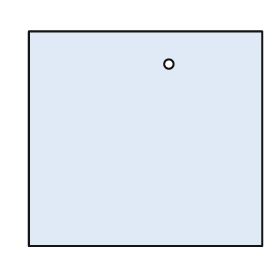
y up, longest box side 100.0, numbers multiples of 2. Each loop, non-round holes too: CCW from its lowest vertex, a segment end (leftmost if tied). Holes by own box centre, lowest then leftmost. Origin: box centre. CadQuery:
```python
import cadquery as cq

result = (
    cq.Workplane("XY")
    .moveTo(-50.0, -46.0)
    .lineTo(50.0, -46.0)
    .lineTo(50.0, 46.0)
    .lineTo(-50.0, 46.0)
    .close()
    .moveTo(10.0, 32.0)
    .circle(2.0)
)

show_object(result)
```